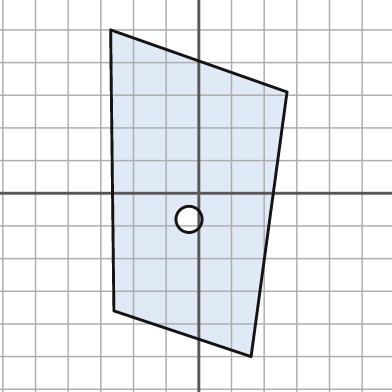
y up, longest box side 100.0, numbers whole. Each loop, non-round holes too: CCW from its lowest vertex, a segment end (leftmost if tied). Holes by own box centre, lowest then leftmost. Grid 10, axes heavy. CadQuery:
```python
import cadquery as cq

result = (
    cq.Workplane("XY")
    .moveTo(16.0, -50.0)
    .lineTo(27.0, 31.0)
    .lineTo(-27.0, 50.0)
    .lineTo(-26.0, -36.0)
    .close()
    .moveTo(-3.0, -8.0)
    .circle(4.0)
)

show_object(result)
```